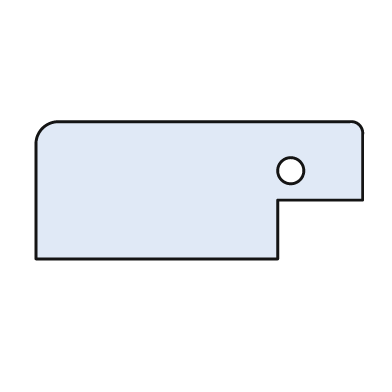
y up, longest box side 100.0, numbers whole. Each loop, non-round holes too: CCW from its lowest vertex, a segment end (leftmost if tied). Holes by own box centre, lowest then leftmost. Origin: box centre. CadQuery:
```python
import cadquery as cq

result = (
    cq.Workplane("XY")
    .moveTo(-50.0, -21.0)
    .lineTo(24.0, -21.0)
    .lineTo(24.0, -3.0)
    .lineTo(50.0, -3.0)
    .lineTo(50.0, 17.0)
    .threePointArc((49.0, 20.0), (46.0, 21.0))
    .lineTo(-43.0, 21.0)
    .threePointArc((-48.0, 19.0), (-50.0, 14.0))
    .close()
    .moveTo(28.0, 6.0)
    .circle(4.0)
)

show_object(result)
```